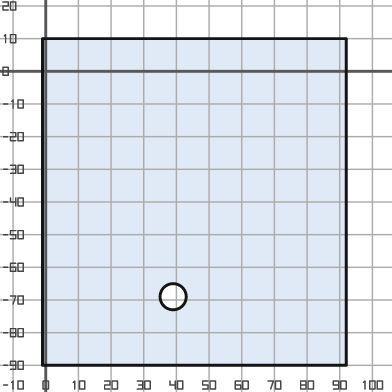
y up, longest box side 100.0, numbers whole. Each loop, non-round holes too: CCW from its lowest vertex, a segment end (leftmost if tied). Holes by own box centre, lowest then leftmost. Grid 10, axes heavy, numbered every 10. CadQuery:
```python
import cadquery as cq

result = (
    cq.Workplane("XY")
    .moveTo(-1.0, -90.0)
    .lineTo(92.0, -90.0)
    .lineTo(92.0, 10.0)
    .lineTo(-1.0, 10.0)
    .close()
    .moveTo(39.0, -69.0)
    .circle(4.0)
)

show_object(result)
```